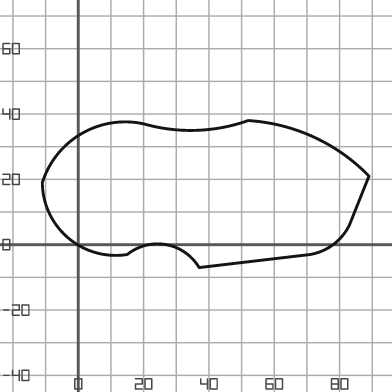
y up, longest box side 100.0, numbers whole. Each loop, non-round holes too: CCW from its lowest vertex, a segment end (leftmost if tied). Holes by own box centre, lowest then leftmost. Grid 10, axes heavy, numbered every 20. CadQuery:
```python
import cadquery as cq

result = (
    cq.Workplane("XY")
    .moveTo(37.0, -7.0)
    .lineTo(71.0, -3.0)
    .threePointArc((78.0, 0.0), (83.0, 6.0))
    .lineTo(89.0, 21.0)
    .threePointArc((72.0, 33.0), (52.0, 38.0))
    .threePointArc((36.0, 35.0), (20.0, 37.0))
    .threePointArc((1.0, 34.0), (-11.0, 19.0))
    .threePointArc((-3.0, 2.0), (15.0, -3.0))
    .threePointArc((27.0, 0.0), (37.0, -7.0))
    .close()
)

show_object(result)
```